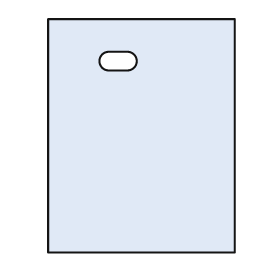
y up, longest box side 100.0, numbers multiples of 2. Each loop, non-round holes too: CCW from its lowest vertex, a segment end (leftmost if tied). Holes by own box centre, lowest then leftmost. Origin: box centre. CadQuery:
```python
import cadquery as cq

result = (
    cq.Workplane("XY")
    .moveTo(-40.0, -50.0)
    .lineTo(40.0, -50.0)
    .lineTo(40.0, 50.0)
    .lineTo(-40.0, 50.0)
    .close()
    .moveTo(-14.0, 28.0)
    .lineTo(-6.0, 28.0)
    .threePointArc((-2.0, 32.0), (-6.0, 36.0))
    .lineTo(-14.0, 36.0)
    .threePointArc((-18.0, 32.0), (-14.0, 28.0))
    .close()
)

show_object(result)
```